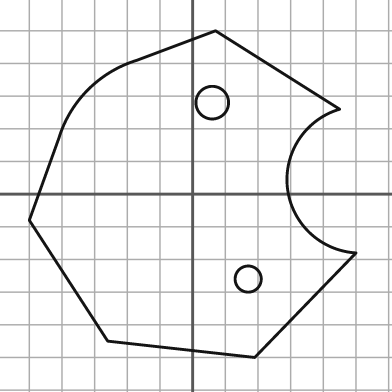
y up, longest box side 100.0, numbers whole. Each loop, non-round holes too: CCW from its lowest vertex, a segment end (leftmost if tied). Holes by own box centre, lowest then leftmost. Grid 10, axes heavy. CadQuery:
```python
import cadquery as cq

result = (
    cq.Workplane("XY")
    .moveTo(19.0, -50.0)
    .lineTo(50.0, -18.0)
    .threePointArc((29.0, 2.0), (45.0, 26.0))
    .lineTo(7.0, 50.0)
    .lineTo(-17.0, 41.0)
    .threePointArc((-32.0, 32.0), (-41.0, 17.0))
    .lineTo(-50.0, -8.0)
    .lineTo(-26.0, -45.0)
    .close()
    .moveTo(17.0, -26.0)
    .circle(4.0)
    .moveTo(6.0, 28.0)
    .circle(5.0)
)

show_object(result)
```